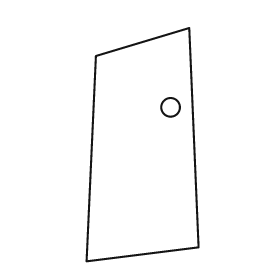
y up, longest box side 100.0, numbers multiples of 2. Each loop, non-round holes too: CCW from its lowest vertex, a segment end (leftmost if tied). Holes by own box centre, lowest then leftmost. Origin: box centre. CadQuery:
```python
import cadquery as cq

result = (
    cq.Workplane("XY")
    .moveTo(-24.0, -50.0)
    .lineTo(24.0, -44.0)
    .lineTo(20.0, 50.0)
    .lineTo(-20.0, 38.0)
    .close()
    .moveTo(12.0, 16.0)
    .circle(4.0)
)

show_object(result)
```